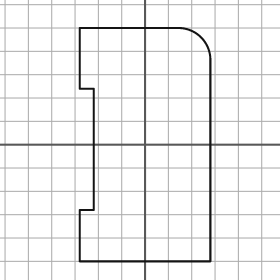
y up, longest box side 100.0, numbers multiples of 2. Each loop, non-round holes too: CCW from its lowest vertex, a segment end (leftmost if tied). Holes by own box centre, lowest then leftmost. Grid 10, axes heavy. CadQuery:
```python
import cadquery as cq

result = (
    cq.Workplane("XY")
    .moveTo(-28.0, -50.0)
    .lineTo(28.0, -50.0)
    .lineTo(28.0, 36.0)
    .threePointArc((24.0, 46.0), (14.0, 50.0))
    .lineTo(-28.0, 50.0)
    .lineTo(-28.0, 24.0)
    .lineTo(-22.0, 24.0)
    .lineTo(-22.0, -28.0)
    .lineTo(-28.0, -28.0)
    .close()
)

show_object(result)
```